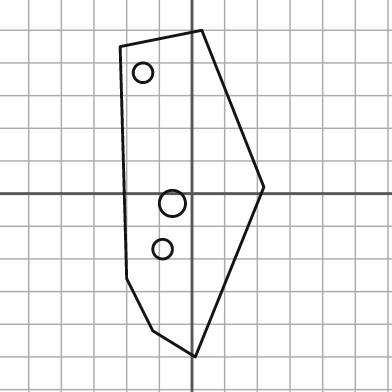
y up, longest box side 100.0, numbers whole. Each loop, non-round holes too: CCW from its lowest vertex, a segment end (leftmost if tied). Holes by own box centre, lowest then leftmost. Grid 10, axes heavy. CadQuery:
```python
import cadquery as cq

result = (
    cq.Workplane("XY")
    .moveTo(1.0, -50.0)
    .lineTo(22.0, 2.0)
    .lineTo(3.0, 50.0)
    .lineTo(-22.0, 45.0)
    .lineTo(-20.0, -26.0)
    .lineTo(-12.0, -42.0)
    .close()
    .moveTo(-9.0, -17.0)
    .circle(3.0)
    .moveTo(-6.0, -3.0)
    .circle(4.0)
    .moveTo(-15.0, 37.0)
    .circle(3.0)
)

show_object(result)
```